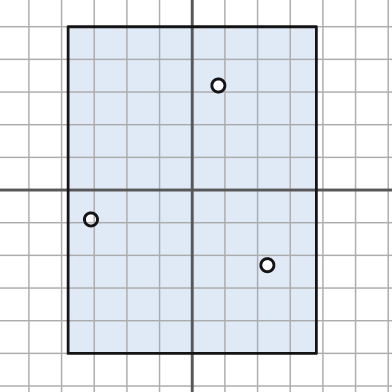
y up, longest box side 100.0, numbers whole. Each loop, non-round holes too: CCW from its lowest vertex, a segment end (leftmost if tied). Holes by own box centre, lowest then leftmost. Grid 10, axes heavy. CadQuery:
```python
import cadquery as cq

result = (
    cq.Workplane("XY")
    .moveTo(-38.0, -50.0)
    .lineTo(38.0, -50.0)
    .lineTo(38.0, 50.0)
    .lineTo(-38.0, 50.0)
    .close()
    .moveTo(23.0, -23.0)
    .circle(2.0)
    .moveTo(-31.0, -9.0)
    .circle(2.0)
    .moveTo(8.0, 32.0)
    .circle(2.0)
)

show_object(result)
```